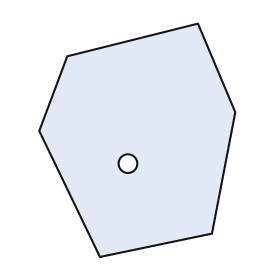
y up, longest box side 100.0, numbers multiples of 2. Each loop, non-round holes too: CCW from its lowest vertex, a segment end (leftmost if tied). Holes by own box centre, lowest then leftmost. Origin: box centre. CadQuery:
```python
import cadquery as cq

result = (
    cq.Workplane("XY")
    .moveTo(-16.0, -50.0)
    .lineTo(32.0, -40.0)
    .lineTo(42.0, 12.0)
    .lineTo(26.0, 50.0)
    .lineTo(-30.0, 36.0)
    .lineTo(-42.0, 4.0)
    .close()
    .moveTo(-4.0, -10.0)
    .circle(4.0)
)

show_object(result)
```